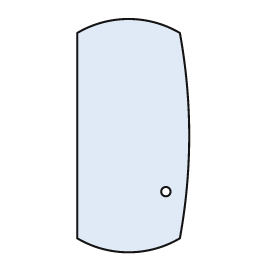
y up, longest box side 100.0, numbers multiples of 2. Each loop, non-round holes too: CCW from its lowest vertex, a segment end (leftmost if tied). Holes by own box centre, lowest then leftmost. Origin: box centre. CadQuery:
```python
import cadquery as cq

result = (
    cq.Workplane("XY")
    .moveTo(-24.0, -44.0)
    .threePointArc((-2.0, -50.0), (20.0, -44.0))
    .threePointArc((24.0, 0.0), (20.0, 44.0))
    .threePointArc((-2.0, 50.0), (-24.0, 44.0))
    .close()
    .moveTo(14.0, -24.0)
    .circle(2.0)
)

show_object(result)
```